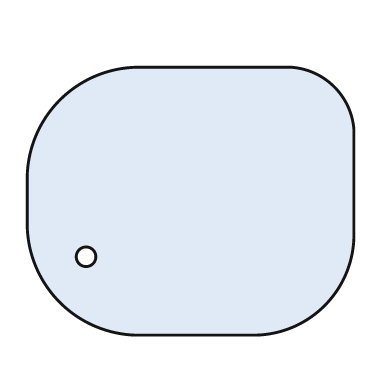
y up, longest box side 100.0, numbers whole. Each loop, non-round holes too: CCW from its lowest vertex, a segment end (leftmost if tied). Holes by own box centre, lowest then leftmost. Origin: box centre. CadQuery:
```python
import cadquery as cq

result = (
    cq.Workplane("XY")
    .moveTo(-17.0, -41.0)
    .lineTo(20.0, -41.0)
    .threePointArc((41.0, -32.0), (50.0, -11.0))
    .lineTo(50.0, 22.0)
    .threePointArc((44.0, 35.0), (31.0, 41.0))
    .lineTo(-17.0, 41.0)
    .threePointArc((-40.0, 31.0), (-50.0, 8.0))
    .lineTo(-50.0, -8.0)
    .threePointArc((-40.0, -31.0), (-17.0, -41.0))
    .close()
    .moveTo(-32.0, -17.0)
    .circle(3.0)
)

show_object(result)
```